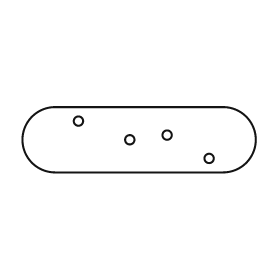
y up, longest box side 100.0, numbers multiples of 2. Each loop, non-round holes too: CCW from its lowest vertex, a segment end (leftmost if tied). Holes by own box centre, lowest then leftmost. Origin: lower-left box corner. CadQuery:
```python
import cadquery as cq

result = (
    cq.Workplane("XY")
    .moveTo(14.0, 0.0)
    .lineTo(86.0, 0.0)
    .threePointArc((100.0, 14.0), (86.0, 28.0))
    .lineTo(14.0, 28.0)
    .threePointArc((0.0, 14.0), (14.0, 0.0))
    .close()
    .moveTo(80.0, 6.0)
    .circle(2.0)
    .moveTo(46.0, 14.0)
    .circle(2.0)
    .moveTo(62.0, 16.0)
    .circle(2.0)
    .moveTo(24.0, 22.0)
    .circle(2.0)
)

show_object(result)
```